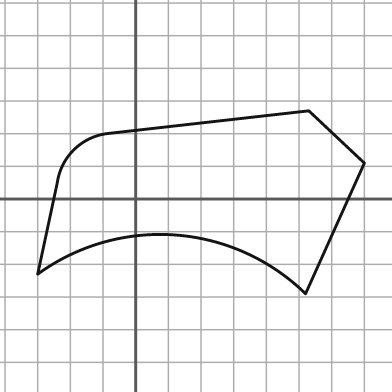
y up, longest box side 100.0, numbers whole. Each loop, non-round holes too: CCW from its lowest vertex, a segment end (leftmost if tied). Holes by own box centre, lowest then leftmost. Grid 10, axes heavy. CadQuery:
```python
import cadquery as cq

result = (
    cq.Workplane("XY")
    .moveTo(52.0, -29.0)
    .lineTo(70.0, 11.0)
    .lineTo(53.0, 27.0)
    .lineTo(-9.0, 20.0)
    .threePointArc((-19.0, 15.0), (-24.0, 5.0))
    .lineTo(-30.0, -23.0)
    .threePointArc((12.0, -11.0), (52.0, -29.0))
    .close()
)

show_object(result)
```